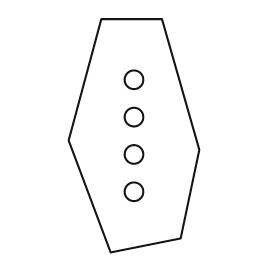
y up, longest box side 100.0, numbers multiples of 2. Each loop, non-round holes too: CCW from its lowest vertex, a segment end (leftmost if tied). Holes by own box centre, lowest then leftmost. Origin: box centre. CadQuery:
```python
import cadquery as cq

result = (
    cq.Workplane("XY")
    .moveTo(-10.0, -50.0)
    .lineTo(20.0, -44.0)
    .lineTo(28.0, -6.0)
    .lineTo(12.0, 50.0)
    .lineTo(-14.0, 50.0)
    .lineTo(-28.0, -2.0)
    .close()
    .moveTo(0.0, -24.0)
    .circle(4.0)
    .moveTo(0.0, -8.0)
    .circle(4.0)
    .moveTo(0.0, 8.0)
    .circle(4.0)
    .moveTo(0.0, 24.0)
    .circle(4.0)
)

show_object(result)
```